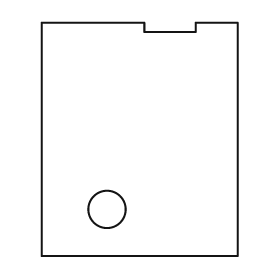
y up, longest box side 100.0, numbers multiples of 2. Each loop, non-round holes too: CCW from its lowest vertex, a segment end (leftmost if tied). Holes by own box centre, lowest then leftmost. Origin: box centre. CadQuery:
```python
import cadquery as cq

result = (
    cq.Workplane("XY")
    .moveTo(-42.0, -50.0)
    .lineTo(42.0, -50.0)
    .lineTo(42.0, 50.0)
    .lineTo(24.0, 50.0)
    .lineTo(24.0, 46.0)
    .lineTo(2.0, 46.0)
    .lineTo(2.0, 50.0)
    .lineTo(-42.0, 50.0)
    .close()
    .moveTo(-14.0, -30.0)
    .circle(8.0)
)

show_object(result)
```